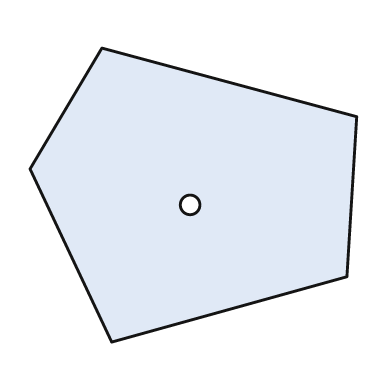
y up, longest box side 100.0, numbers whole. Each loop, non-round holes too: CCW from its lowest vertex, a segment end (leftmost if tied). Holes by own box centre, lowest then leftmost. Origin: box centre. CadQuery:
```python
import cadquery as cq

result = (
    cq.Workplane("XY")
    .moveTo(-25.0, -45.0)
    .lineTo(47.0, -25.0)
    .lineTo(50.0, 24.0)
    .lineTo(-28.0, 45.0)
    .lineTo(-50.0, 8.0)
    .close()
    .moveTo(-1.0, -3.0)
    .circle(3.0)
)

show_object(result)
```